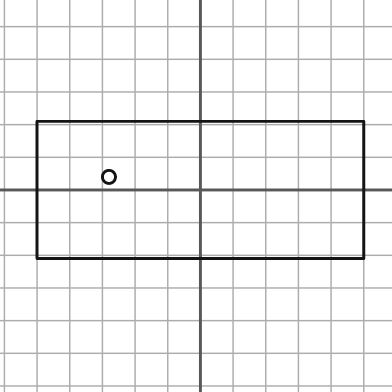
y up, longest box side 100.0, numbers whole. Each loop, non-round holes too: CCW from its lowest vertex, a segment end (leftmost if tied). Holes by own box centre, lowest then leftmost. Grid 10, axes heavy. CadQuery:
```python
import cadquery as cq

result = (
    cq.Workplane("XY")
    .moveTo(-50.0, -21.0)
    .lineTo(50.0, -21.0)
    .lineTo(50.0, 21.0)
    .lineTo(-50.0, 21.0)
    .close()
    .moveTo(-28.0, 4.0)
    .circle(2.0)
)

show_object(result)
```